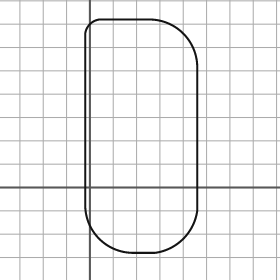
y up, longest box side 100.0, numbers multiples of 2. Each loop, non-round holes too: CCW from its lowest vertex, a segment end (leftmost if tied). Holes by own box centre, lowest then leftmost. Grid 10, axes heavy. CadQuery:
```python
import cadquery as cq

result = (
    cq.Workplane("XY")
    .moveTo(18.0, -28.0)
    .lineTo(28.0, -28.0)
    .threePointArc((40.0, -22.0), (46.0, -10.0))
    .lineTo(46.0, 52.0)
    .threePointArc((40.0, 66.0), (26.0, 72.0))
    .lineTo(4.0, 72.0)
    .threePointArc((0.0, 70.0), (-2.0, 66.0))
    .lineTo(-2.0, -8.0)
    .threePointArc((4.0, -22.0), (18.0, -28.0))
    .close()
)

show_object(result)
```